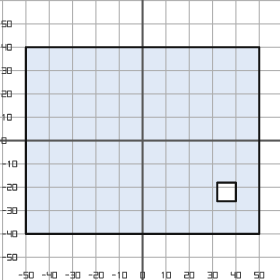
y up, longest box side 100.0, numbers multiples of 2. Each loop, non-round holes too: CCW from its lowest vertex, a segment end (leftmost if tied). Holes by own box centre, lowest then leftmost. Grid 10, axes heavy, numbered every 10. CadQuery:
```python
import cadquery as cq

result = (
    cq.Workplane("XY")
    .moveTo(-50.0, -40.0)
    .lineTo(50.0, -40.0)
    .lineTo(50.0, 40.0)
    .lineTo(-50.0, 40.0)
    .close()
    .moveTo(32.0, -26.0)
    .lineTo(40.0, -26.0)
    .lineTo(40.0, -18.0)
    .lineTo(32.0, -18.0)
    .close()
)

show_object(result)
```